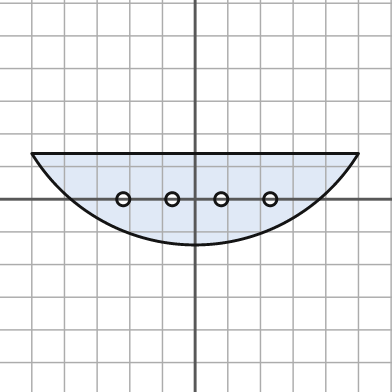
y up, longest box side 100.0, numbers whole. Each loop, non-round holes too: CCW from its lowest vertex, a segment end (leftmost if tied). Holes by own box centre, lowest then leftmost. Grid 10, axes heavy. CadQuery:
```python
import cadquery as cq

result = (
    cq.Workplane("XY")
    .moveTo(-50.0, 14.0)
    .threePointArc((0.0, -14.0), (50.0, 14.0))
    .close()
    .moveTo(-22.0, 0.0)
    .circle(2.0)
    .moveTo(-7.0, 0.0)
    .circle(2.0)
    .moveTo(8.0, 0.0)
    .circle(2.0)
    .moveTo(23.0, 0.0)
    .circle(2.0)
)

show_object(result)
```